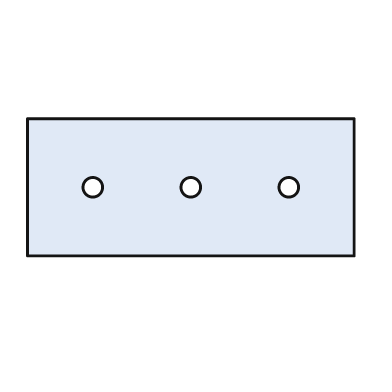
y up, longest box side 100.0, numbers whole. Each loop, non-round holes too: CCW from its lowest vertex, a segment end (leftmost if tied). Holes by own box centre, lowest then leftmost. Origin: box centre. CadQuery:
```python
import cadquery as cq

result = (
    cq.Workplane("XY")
    .moveTo(-50.0, -21.0)
    .lineTo(50.0, -21.0)
    .lineTo(50.0, 21.0)
    .lineTo(-50.0, 21.0)
    .close()
    .moveTo(-30.0, 0.0)
    .circle(3.0)
    .moveTo(0.0, 0.0)
    .circle(3.0)
    .moveTo(30.0, 0.0)
    .circle(3.0)
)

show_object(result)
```